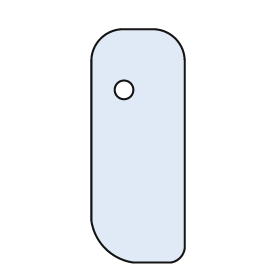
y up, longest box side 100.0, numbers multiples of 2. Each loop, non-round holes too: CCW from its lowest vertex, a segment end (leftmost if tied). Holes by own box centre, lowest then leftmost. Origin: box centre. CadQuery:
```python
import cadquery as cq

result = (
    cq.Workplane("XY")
    .moveTo(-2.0, -50.0)
    .lineTo(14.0, -50.0)
    .threePointArc((18.0, -48.0), (20.0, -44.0))
    .lineTo(20.0, 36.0)
    .threePointArc((16.0, 46.0), (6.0, 50.0))
    .lineTo(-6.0, 50.0)
    .threePointArc((-16.0, 46.0), (-20.0, 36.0))
    .lineTo(-20.0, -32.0)
    .threePointArc((-14.0, -44.0), (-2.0, -50.0))
    .close()
    .moveTo(-6.0, 24.0)
    .circle(4.0)
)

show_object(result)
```